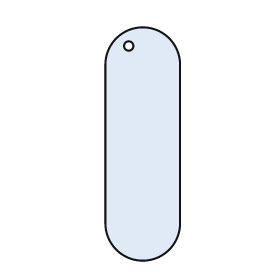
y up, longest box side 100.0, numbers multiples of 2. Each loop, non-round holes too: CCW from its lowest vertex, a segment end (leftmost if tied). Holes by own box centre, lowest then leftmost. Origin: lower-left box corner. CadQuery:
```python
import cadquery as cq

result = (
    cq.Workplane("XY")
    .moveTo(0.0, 16.0)
    .threePointArc((16.0, 0.0), (32.0, 16.0))
    .lineTo(32.0, 84.0)
    .threePointArc((16.0, 100.0), (0.0, 84.0))
    .close()
    .moveTo(10.0, 92.0)
    .circle(2.0)
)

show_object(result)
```